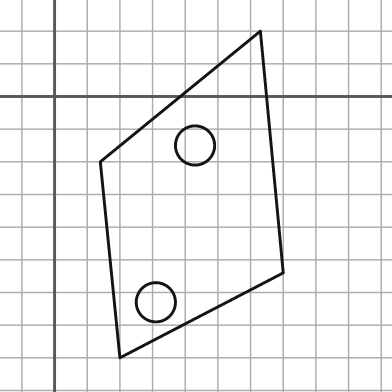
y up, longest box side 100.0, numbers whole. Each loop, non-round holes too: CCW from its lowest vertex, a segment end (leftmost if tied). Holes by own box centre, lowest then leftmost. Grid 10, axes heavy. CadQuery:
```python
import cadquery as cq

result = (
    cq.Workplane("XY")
    .moveTo(20.0, -80.0)
    .lineTo(70.0, -54.0)
    .lineTo(63.0, 20.0)
    .lineTo(14.0, -20.0)
    .close()
    .moveTo(31.0, -63.0)
    .circle(6.0)
    .moveTo(43.0, -15.0)
    .circle(6.0)
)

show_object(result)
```